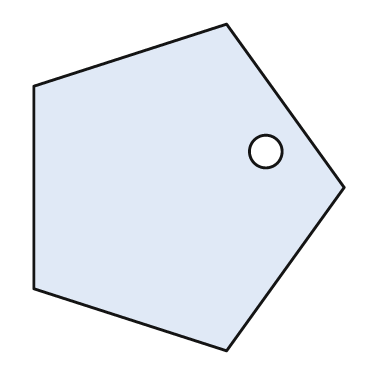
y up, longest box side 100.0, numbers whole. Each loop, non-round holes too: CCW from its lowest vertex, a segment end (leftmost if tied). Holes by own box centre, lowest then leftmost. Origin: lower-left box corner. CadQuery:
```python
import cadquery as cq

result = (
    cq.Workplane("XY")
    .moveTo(59.0, 0.0)
    .lineTo(95.0, 50.0)
    .lineTo(59.0, 100.0)
    .lineTo(0.0, 81.0)
    .lineTo(0.0, 19.0)
    .close()
    .moveTo(71.0, 61.0)
    .circle(5.0)
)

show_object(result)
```